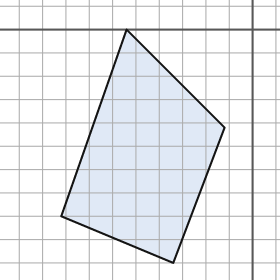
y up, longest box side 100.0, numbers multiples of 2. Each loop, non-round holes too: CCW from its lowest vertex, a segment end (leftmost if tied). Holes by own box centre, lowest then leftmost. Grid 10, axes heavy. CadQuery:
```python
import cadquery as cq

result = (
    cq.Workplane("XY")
    .moveTo(-34.0, -100.0)
    .lineTo(-12.0, -42.0)
    .lineTo(-54.0, 0.0)
    .lineTo(-82.0, -80.0)
    .close()
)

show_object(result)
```